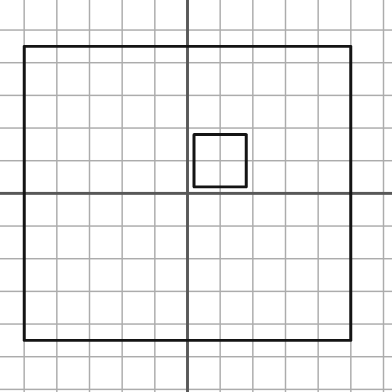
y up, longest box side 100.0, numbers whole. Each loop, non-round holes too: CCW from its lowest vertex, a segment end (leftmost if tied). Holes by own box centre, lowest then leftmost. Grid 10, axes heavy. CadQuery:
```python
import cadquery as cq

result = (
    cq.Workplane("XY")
    .moveTo(-50.0, -45.0)
    .lineTo(50.0, -45.0)
    .lineTo(50.0, 45.0)
    .lineTo(-50.0, 45.0)
    .close()
    .moveTo(2.0, 2.0)
    .lineTo(18.0, 2.0)
    .lineTo(18.0, 18.0)
    .lineTo(2.0, 18.0)
    .close()
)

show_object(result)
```